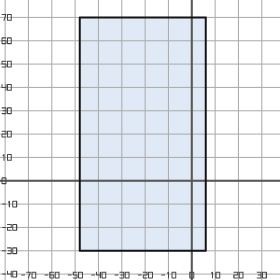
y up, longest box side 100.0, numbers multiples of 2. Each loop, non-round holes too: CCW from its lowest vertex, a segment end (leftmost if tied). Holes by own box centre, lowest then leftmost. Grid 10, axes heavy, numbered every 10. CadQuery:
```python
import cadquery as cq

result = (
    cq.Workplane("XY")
    .moveTo(-48.0, -30.0)
    .lineTo(6.0, -30.0)
    .lineTo(6.0, 70.0)
    .lineTo(-48.0, 70.0)
    .close()
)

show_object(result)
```